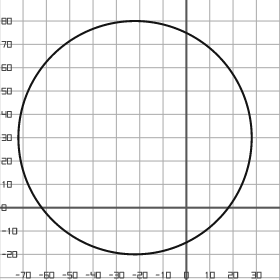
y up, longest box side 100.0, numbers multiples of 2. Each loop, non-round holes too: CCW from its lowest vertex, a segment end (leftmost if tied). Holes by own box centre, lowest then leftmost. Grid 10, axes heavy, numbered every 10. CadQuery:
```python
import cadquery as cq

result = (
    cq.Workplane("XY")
    .moveTo(-22.0, 30.0)
    .circle(50.0)
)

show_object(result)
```